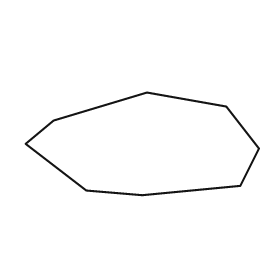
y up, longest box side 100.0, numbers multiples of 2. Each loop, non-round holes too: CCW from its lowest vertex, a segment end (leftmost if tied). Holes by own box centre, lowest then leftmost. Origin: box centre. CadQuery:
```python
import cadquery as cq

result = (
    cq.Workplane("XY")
    .moveTo(0.0, -22.0)
    .lineTo(42.0, -18.0)
    .lineTo(50.0, -2.0)
    .lineTo(36.0, 16.0)
    .lineTo(2.0, 22.0)
    .lineTo(-38.0, 10.0)
    .lineTo(-50.0, 0.0)
    .lineTo(-24.0, -20.0)
    .close()
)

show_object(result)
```